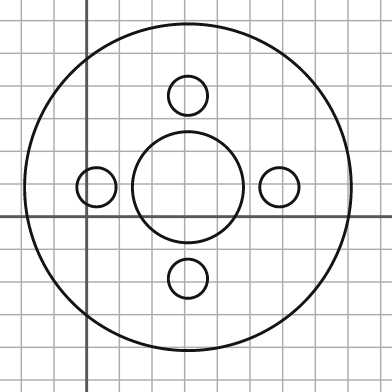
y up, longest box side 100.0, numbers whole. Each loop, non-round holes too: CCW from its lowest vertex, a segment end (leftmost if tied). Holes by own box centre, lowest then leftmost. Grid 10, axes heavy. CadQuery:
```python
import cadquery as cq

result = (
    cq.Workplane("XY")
    .moveTo(31.0, 9.0)
    .circle(50.0)
    .moveTo(31.0, -19.0)
    .circle(6.0)
    .moveTo(3.0, 9.0)
    .circle(6.0)
    .moveTo(31.0, 9.0)
    .circle(17.0)
    .moveTo(59.0, 9.0)
    .circle(6.0)
    .moveTo(31.0, 37.0)
    .circle(6.0)
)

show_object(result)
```